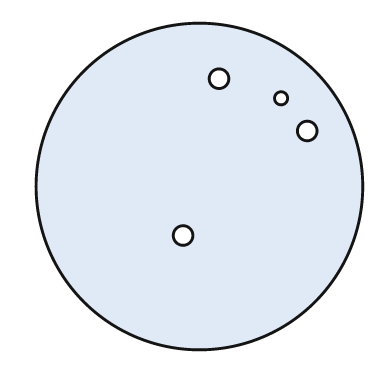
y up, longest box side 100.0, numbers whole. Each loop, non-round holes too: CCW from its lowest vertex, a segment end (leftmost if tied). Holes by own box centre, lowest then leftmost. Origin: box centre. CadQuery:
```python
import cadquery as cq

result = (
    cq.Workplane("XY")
    .moveTo(0.0, 0.0)
    .circle(50.0)
    .moveTo(-5.0, -15.0)
    .circle(3.0)
    .moveTo(33.0, 17.0)
    .circle(3.0)
    .moveTo(25.0, 27.0)
    .circle(2.0)
    .moveTo(6.0, 33.0)
    .circle(3.0)
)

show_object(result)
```